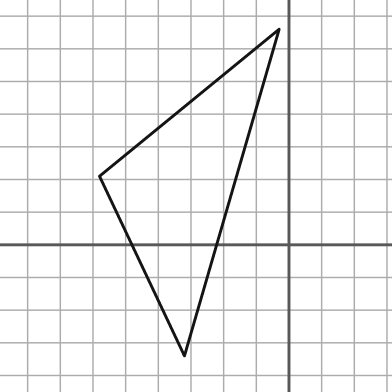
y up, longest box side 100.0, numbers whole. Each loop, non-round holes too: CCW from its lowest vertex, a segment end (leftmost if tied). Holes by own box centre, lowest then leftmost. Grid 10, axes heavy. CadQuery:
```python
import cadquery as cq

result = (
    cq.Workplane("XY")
    .moveTo(-32.0, -34.0)
    .lineTo(-3.0, 66.0)
    .lineTo(-58.0, 21.0)
    .close()
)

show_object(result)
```